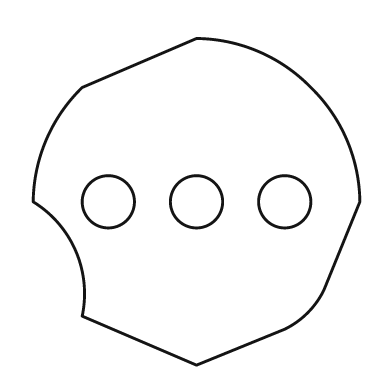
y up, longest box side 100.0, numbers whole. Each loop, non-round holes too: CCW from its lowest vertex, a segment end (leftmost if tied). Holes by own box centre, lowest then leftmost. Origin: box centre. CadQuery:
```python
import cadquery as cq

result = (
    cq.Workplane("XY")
    .moveTo(0.0, -50.0)
    .lineTo(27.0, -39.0)
    .threePointArc((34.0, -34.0), (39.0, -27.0))
    .lineTo(50.0, 0.0)
    .threePointArc((46.0, 19.0), (35.0, 35.0))
    .threePointArc((19.0, 46.0), (0.0, 50.0))
    .lineTo(-35.0, 35.0)
    .threePointArc((-46.0, 19.0), (-50.0, 0.0))
    .threePointArc((-37.0, -15.0), (-35.0, -35.0))
    .close()
    .moveTo(-27.0, 0.0)
    .circle(8.0)
    .moveTo(0.0, 0.0)
    .circle(8.0)
    .moveTo(27.0, 0.0)
    .circle(8.0)
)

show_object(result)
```